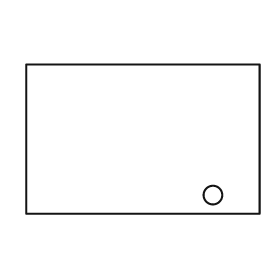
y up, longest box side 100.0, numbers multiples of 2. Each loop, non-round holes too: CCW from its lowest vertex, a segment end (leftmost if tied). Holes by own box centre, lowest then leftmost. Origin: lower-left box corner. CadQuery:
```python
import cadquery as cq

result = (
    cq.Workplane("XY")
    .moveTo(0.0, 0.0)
    .lineTo(100.0, 0.0)
    .lineTo(100.0, 64.0)
    .lineTo(0.0, 64.0)
    .close()
    .moveTo(80.0, 8.0)
    .circle(4.0)
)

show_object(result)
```